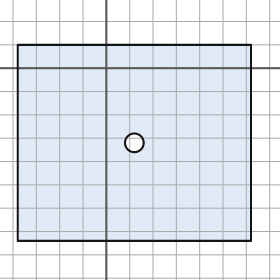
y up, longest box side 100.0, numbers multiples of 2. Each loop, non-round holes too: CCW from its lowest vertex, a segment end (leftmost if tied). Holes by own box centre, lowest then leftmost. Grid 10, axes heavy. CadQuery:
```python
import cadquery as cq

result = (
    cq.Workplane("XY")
    .moveTo(-38.0, -74.0)
    .lineTo(62.0, -74.0)
    .lineTo(62.0, 10.0)
    .lineTo(-38.0, 10.0)
    .close()
    .moveTo(12.0, -32.0)
    .circle(4.0)
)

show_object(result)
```